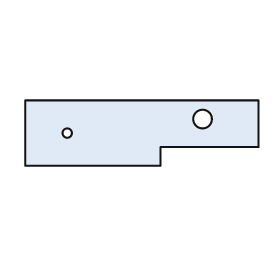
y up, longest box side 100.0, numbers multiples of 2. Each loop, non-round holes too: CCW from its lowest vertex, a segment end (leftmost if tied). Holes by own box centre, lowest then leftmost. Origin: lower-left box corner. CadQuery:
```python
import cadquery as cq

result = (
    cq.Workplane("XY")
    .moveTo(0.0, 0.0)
    .lineTo(58.0, 0.0)
    .lineTo(58.0, 8.0)
    .lineTo(100.0, 8.0)
    .lineTo(100.0, 28.0)
    .lineTo(0.0, 28.0)
    .close()
    .moveTo(18.0, 14.0)
    .circle(2.0)
    .moveTo(76.0, 20.0)
    .circle(4.0)
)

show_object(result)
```